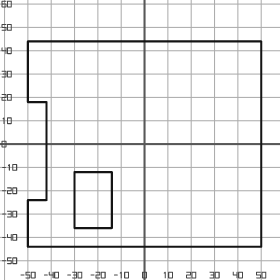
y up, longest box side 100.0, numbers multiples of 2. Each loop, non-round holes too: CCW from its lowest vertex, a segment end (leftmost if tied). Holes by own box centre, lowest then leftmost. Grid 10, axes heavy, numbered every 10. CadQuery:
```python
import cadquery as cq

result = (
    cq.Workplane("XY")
    .moveTo(-50.0, -44.0)
    .lineTo(50.0, -44.0)
    .lineTo(50.0, 44.0)
    .lineTo(-50.0, 44.0)
    .lineTo(-50.0, 18.0)
    .lineTo(-42.0, 18.0)
    .lineTo(-42.0, -24.0)
    .lineTo(-50.0, -24.0)
    .close()
    .moveTo(-30.0, -36.0)
    .lineTo(-14.0, -36.0)
    .lineTo(-14.0, -12.0)
    .lineTo(-30.0, -12.0)
    .close()
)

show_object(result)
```